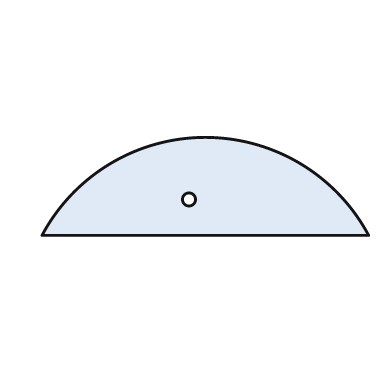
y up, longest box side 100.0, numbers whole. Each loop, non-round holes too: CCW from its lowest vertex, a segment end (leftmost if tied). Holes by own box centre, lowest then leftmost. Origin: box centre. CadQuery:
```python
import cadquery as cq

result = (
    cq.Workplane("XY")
    .moveTo(-50.0, -15.0)
    .lineTo(50.0, -15.0)
    .threePointArc((0.0, 15.0), (-50.0, -15.0))
    .close()
    .moveTo(-5.0, -4.0)
    .circle(2.0)
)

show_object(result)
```